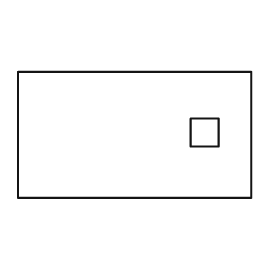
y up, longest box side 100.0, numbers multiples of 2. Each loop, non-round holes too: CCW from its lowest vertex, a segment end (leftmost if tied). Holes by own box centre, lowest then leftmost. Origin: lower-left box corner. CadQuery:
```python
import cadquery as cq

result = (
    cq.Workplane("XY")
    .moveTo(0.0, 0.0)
    .lineTo(100.0, 0.0)
    .lineTo(100.0, 54.0)
    .lineTo(0.0, 54.0)
    .close()
    .moveTo(74.0, 22.0)
    .lineTo(86.0, 22.0)
    .lineTo(86.0, 34.0)
    .lineTo(74.0, 34.0)
    .close()
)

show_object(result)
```